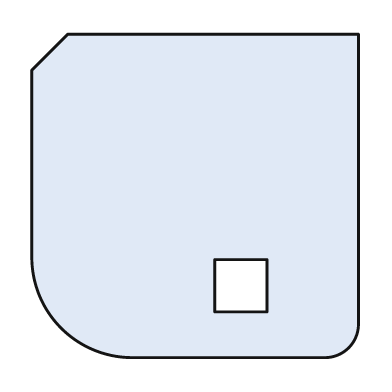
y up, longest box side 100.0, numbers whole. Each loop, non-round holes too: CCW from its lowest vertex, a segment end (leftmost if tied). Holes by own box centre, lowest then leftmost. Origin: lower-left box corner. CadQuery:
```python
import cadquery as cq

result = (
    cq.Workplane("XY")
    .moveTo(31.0, 0.0)
    .lineTo(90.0, 0.0)
    .threePointArc((97.0, 3.0), (100.0, 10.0))
    .lineTo(100.0, 99.0)
    .lineTo(11.0, 99.0)
    .lineTo(0.0, 88.0)
    .lineTo(0.0, 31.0)
    .threePointArc((9.0, 9.0), (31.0, 0.0))
    .close()
    .moveTo(56.0, 14.0)
    .lineTo(72.0, 14.0)
    .lineTo(72.0, 30.0)
    .lineTo(56.0, 30.0)
    .close()
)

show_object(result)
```